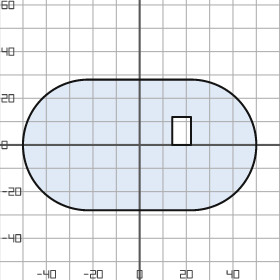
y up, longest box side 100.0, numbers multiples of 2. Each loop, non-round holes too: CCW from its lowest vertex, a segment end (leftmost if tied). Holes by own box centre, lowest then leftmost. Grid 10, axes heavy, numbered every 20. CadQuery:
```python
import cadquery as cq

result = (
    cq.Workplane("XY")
    .moveTo(-22.0, -28.0)
    .lineTo(22.0, -28.0)
    .threePointArc((50.0, 0.0), (22.0, 28.0))
    .lineTo(-22.0, 28.0)
    .threePointArc((-50.0, 0.0), (-22.0, -28.0))
    .close()
    .moveTo(14.0, 0.0)
    .lineTo(22.0, 0.0)
    .lineTo(22.0, 12.0)
    .lineTo(14.0, 12.0)
    .close()
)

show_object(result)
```